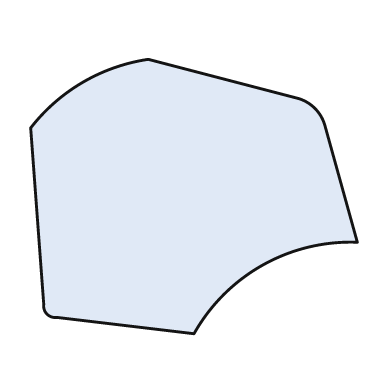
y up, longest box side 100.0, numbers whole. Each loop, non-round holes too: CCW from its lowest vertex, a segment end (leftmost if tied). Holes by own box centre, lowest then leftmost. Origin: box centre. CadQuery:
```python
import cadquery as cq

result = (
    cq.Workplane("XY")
    .moveTo(0.0, -42.0)
    .threePointArc((21.0, -21.0), (50.0, -14.0))
    .lineTo(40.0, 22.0)
    .threePointArc((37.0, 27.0), (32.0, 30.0))
    .lineTo(-14.0, 42.0)
    .threePointArc((-34.0, 35.0), (-50.0, 21.0))
    .lineTo(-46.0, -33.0)
    .threePointArc((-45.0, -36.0), (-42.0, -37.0))
    .close()
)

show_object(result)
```